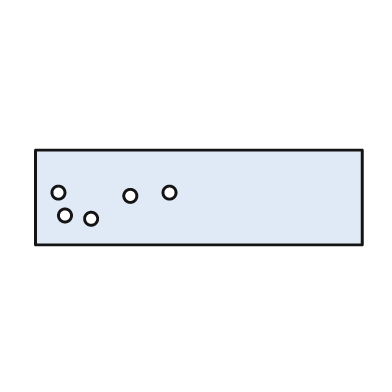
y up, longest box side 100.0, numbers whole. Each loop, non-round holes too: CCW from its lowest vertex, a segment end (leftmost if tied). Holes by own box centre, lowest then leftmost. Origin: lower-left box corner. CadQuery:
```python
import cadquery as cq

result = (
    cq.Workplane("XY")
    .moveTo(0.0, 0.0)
    .lineTo(100.0, 0.0)
    .lineTo(100.0, 29.0)
    .lineTo(0.0, 29.0)
    .close()
    .moveTo(17.0, 8.0)
    .circle(2.0)
    .moveTo(9.0, 9.0)
    .circle(2.0)
    .moveTo(29.0, 15.0)
    .circle(2.0)
    .moveTo(7.0, 16.0)
    .circle(2.0)
    .moveTo(41.0, 16.0)
    .circle(2.0)
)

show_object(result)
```